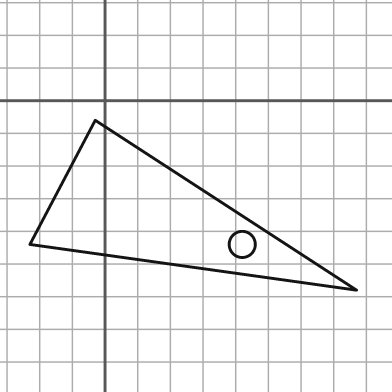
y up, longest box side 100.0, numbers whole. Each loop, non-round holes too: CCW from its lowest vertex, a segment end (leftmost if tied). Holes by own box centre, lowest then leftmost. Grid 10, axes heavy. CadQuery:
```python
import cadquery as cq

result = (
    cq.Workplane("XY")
    .moveTo(77.0, -58.0)
    .lineTo(-3.0, -6.0)
    .lineTo(-23.0, -44.0)
    .close()
    .moveTo(42.0, -44.0)
    .circle(4.0)
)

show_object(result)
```